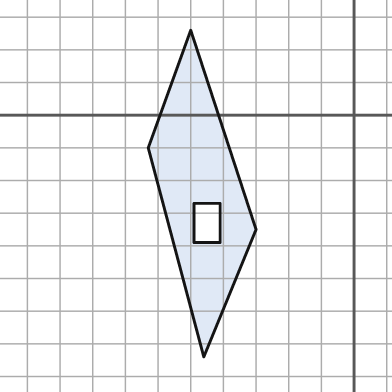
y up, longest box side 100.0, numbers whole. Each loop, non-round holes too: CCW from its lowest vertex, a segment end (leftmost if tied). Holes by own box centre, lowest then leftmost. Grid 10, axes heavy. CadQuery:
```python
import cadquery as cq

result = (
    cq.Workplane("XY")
    .moveTo(-46.0, -74.0)
    .lineTo(-30.0, -35.0)
    .lineTo(-50.0, 26.0)
    .lineTo(-63.0, -10.0)
    .close()
    .moveTo(-49.0, -39.0)
    .lineTo(-41.0, -39.0)
    .lineTo(-41.0, -27.0)
    .lineTo(-49.0, -27.0)
    .close()
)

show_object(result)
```